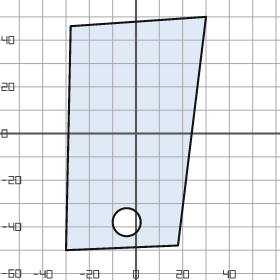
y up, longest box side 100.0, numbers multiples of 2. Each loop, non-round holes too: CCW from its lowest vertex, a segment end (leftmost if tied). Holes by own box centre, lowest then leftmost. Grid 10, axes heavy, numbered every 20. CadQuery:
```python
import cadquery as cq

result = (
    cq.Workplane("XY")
    .moveTo(-30.0, -50.0)
    .lineTo(18.0, -48.0)
    .lineTo(30.0, 50.0)
    .lineTo(-28.0, 46.0)
    .close()
    .moveTo(-4.0, -38.0)
    .circle(6.0)
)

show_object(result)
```